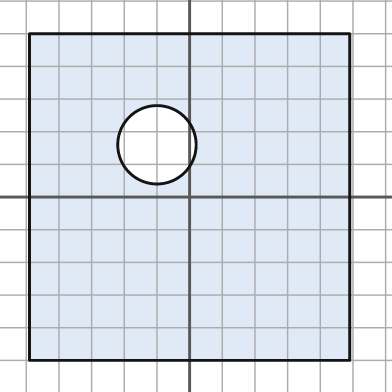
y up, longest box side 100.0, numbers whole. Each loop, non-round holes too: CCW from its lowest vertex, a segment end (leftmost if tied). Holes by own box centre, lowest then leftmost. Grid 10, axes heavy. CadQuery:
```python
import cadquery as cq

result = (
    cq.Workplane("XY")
    .moveTo(-49.0, -50.0)
    .lineTo(49.0, -50.0)
    .lineTo(49.0, 50.0)
    .lineTo(-49.0, 50.0)
    .close()
    .moveTo(-10.0, 16.0)
    .circle(12.0)
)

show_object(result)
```